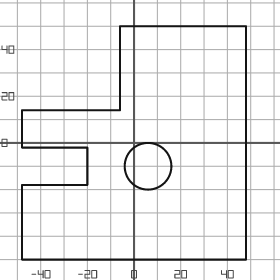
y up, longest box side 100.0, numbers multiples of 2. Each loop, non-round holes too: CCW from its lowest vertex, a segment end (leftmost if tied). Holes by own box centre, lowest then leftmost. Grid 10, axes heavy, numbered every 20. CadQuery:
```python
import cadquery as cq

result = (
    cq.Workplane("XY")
    .moveTo(-48.0, -50.0)
    .lineTo(48.0, -50.0)
    .lineTo(48.0, 50.0)
    .lineTo(-6.0, 50.0)
    .lineTo(-6.0, 14.0)
    .lineTo(-48.0, 14.0)
    .lineTo(-48.0, -2.0)
    .lineTo(-20.0, -2.0)
    .lineTo(-20.0, -18.0)
    .lineTo(-48.0, -18.0)
    .close()
    .moveTo(6.0, -10.0)
    .circle(10.0)
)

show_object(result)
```